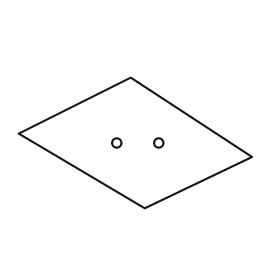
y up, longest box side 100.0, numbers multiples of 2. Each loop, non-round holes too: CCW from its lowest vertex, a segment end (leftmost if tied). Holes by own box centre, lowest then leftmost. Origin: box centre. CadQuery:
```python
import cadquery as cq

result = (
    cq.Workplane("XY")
    .moveTo(4.0, -28.0)
    .lineTo(50.0, -6.0)
    .lineTo(-2.0, 28.0)
    .lineTo(-50.0, 4.0)
    .close()
    .moveTo(-8.0, 0.0)
    .circle(2.0)
    .moveTo(10.0, 0.0)
    .circle(2.0)
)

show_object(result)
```